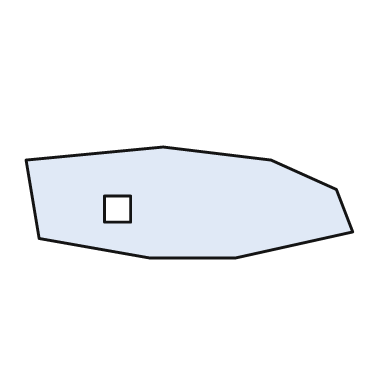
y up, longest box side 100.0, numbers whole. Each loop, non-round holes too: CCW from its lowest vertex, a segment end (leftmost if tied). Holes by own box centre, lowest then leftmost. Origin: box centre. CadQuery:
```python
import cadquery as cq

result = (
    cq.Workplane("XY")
    .moveTo(-12.0, -17.0)
    .lineTo(14.0, -17.0)
    .lineTo(50.0, -9.0)
    .lineTo(45.0, 4.0)
    .lineTo(25.0, 13.0)
    .lineTo(-8.0, 17.0)
    .lineTo(-50.0, 13.0)
    .lineTo(-46.0, -11.0)
    .close()
    .moveTo(-26.0, -6.0)
    .lineTo(-18.0, -6.0)
    .lineTo(-18.0, 2.0)
    .lineTo(-26.0, 2.0)
    .close()
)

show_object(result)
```